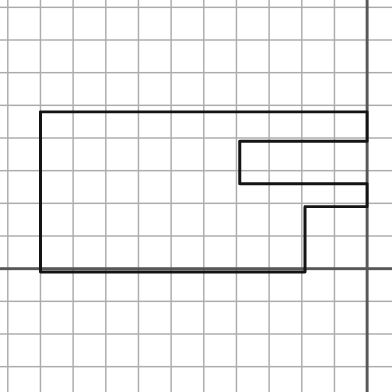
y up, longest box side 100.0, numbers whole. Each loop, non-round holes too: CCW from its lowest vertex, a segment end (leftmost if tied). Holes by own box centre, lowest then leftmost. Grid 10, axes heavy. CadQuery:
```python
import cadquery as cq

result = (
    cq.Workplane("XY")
    .moveTo(-100.0, -1.0)
    .lineTo(-19.0, -1.0)
    .lineTo(-19.0, 19.0)
    .lineTo(0.0, 19.0)
    .lineTo(0.0, 26.0)
    .lineTo(-39.0, 26.0)
    .lineTo(-39.0, 39.0)
    .lineTo(0.0, 39.0)
    .lineTo(0.0, 48.0)
    .lineTo(-100.0, 48.0)
    .close()
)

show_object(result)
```